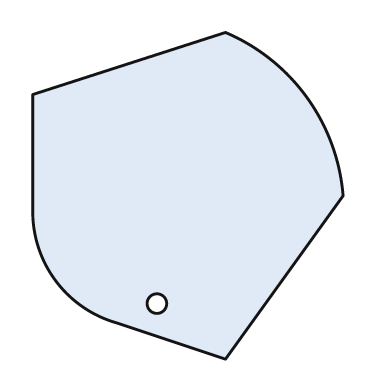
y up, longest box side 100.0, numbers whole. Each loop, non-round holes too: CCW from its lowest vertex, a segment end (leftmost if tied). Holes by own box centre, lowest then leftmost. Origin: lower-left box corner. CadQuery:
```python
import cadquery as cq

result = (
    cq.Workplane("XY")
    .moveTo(59.0, 0.0)
    .lineTo(95.0, 50.0)
    .threePointArc((84.0, 80.0), (59.0, 100.0))
    .lineTo(0.0, 81.0)
    .lineTo(0.0, 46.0)
    .threePointArc((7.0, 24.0), (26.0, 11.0))
    .close()
    .moveTo(38.0, 17.0)
    .circle(3.0)
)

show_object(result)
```